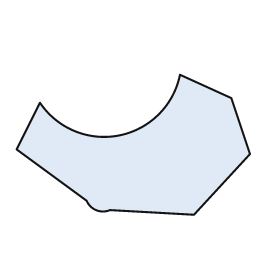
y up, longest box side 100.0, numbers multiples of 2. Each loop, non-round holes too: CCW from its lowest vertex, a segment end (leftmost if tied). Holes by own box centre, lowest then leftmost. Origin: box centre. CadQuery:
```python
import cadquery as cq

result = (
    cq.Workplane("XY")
    .moveTo(26.0, -30.0)
    .lineTo(50.0, -4.0)
    .lineTo(42.0, 20.0)
    .lineTo(20.0, 30.0)
    .threePointArc((-6.0, 4.0), (-40.0, 18.0))
    .lineTo(-50.0, -2.0)
    .lineTo(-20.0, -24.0)
    .threePointArc((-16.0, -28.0), (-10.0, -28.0))
    .close()
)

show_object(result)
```